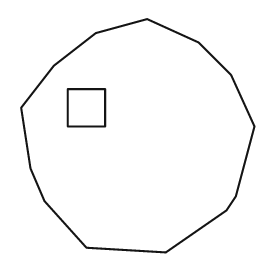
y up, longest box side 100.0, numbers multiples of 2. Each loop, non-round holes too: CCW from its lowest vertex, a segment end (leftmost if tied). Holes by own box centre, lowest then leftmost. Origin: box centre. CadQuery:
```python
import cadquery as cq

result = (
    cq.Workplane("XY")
    .moveTo(12.0, -50.0)
    .lineTo(38.0, -32.0)
    .lineTo(42.0, -26.0)
    .lineTo(50.0, 4.0)
    .lineTo(40.0, 26.0)
    .lineTo(26.0, 40.0)
    .lineTo(4.0, 50.0)
    .lineTo(-18.0, 44.0)
    .lineTo(-36.0, 30.0)
    .lineTo(-50.0, 12.0)
    .lineTo(-46.0, -14.0)
    .lineTo(-40.0, -28.0)
    .lineTo(-22.0, -48.0)
    .close()
    .moveTo(-30.0, 4.0)
    .lineTo(-14.0, 4.0)
    .lineTo(-14.0, 20.0)
    .lineTo(-30.0, 20.0)
    .close()
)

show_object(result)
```